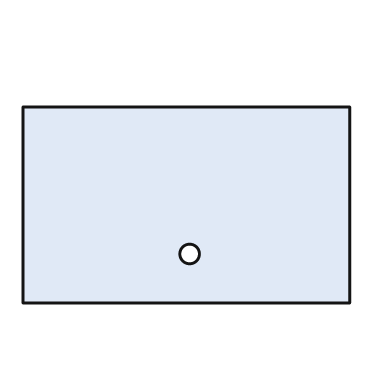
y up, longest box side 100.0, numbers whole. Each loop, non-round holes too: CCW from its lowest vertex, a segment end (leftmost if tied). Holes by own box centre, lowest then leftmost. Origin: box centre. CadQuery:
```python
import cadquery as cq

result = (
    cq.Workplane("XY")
    .moveTo(-50.0, -30.0)
    .lineTo(50.0, -30.0)
    .lineTo(50.0, 30.0)
    .lineTo(-50.0, 30.0)
    .close()
    .moveTo(1.0, -15.0)
    .circle(3.0)
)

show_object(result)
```